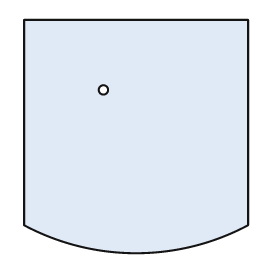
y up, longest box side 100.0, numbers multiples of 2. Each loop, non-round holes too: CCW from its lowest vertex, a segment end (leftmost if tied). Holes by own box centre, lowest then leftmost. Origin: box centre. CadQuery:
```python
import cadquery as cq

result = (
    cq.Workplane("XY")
    .moveTo(-48.0, -38.0)
    .threePointArc((0.0, -50.0), (48.0, -38.0))
    .lineTo(48.0, 50.0)
    .lineTo(-48.0, 50.0)
    .close()
    .moveTo(-14.0, 20.0)
    .circle(2.0)
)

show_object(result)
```